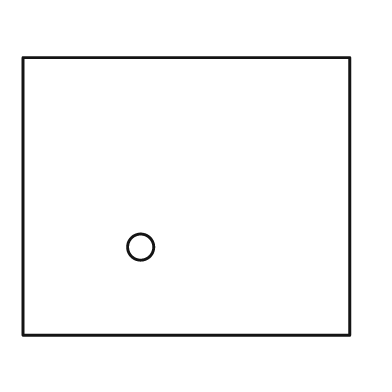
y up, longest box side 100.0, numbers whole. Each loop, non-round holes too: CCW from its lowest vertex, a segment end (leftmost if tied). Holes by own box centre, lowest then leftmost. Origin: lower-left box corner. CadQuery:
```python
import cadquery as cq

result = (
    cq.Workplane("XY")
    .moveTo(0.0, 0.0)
    .lineTo(100.0, 0.0)
    .lineTo(100.0, 85.0)
    .lineTo(0.0, 85.0)
    .close()
    .moveTo(36.0, 27.0)
    .circle(4.0)
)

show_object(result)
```